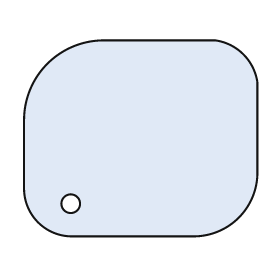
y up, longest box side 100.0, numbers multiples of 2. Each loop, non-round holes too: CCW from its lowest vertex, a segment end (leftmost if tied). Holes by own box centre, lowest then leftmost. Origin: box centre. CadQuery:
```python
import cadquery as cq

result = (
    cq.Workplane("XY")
    .moveTo(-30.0, -42.0)
    .lineTo(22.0, -42.0)
    .threePointArc((42.0, -34.0), (50.0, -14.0))
    .lineTo(50.0, 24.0)
    .threePointArc((44.0, 36.0), (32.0, 42.0))
    .lineTo(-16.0, 42.0)
    .threePointArc((-40.0, 32.0), (-50.0, 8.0))
    .lineTo(-50.0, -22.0)
    .threePointArc((-44.0, -36.0), (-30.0, -42.0))
    .close()
    .moveTo(-30.0, -28.0)
    .circle(4.0)
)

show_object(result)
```